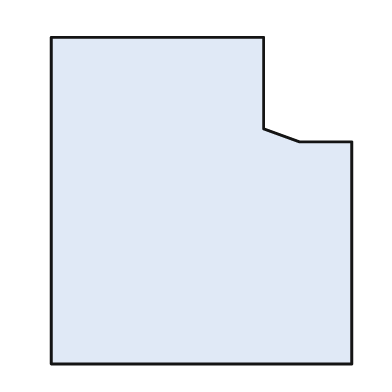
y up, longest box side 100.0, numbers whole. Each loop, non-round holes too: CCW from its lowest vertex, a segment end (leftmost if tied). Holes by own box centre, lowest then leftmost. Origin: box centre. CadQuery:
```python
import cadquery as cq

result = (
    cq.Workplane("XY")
    .moveTo(-46.0, -50.0)
    .lineTo(46.0, -50.0)
    .lineTo(46.0, 18.0)
    .lineTo(30.0, 18.0)
    .lineTo(19.0, 22.0)
    .lineTo(19.0, 50.0)
    .lineTo(-46.0, 50.0)
    .close()
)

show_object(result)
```